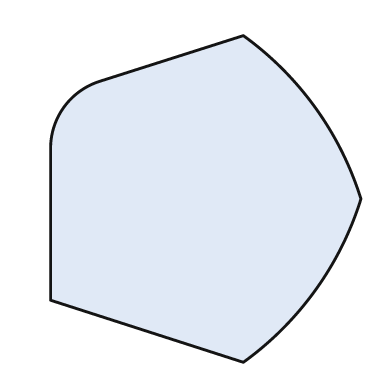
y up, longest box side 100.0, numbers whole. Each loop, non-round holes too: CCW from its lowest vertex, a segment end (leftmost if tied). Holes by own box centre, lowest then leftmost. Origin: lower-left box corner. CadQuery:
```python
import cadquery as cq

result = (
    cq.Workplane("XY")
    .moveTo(59.0, 0.0)
    .threePointArc((81.0, 22.0), (95.0, 50.0))
    .threePointArc((81.0, 78.0), (59.0, 100.0))
    .lineTo(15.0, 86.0)
    .threePointArc((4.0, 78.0), (0.0, 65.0))
    .lineTo(0.0, 19.0)
    .close()
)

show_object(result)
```